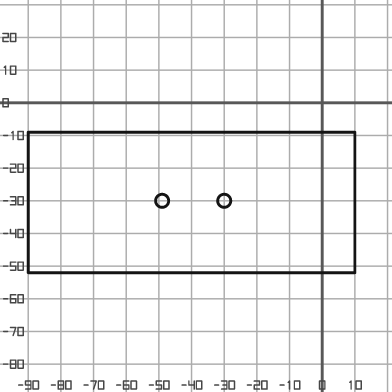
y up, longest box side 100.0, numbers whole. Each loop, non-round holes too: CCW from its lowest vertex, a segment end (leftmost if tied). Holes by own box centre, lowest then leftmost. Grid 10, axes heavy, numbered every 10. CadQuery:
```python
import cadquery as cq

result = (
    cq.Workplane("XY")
    .moveTo(-90.0, -52.0)
    .lineTo(10.0, -52.0)
    .lineTo(10.0, -9.0)
    .lineTo(-90.0, -9.0)
    .close()
    .moveTo(-49.0, -30.0)
    .circle(2.0)
    .moveTo(-30.0, -30.0)
    .circle(2.0)
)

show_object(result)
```